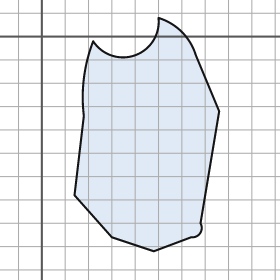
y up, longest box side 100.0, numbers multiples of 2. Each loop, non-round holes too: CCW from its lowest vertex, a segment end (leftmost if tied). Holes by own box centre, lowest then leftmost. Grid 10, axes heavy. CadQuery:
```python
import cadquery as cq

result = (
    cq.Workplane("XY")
    .moveTo(48.0, -92.0)
    .lineTo(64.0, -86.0)
    .threePointArc((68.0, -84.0), (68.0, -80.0))
    .lineTo(76.0, -32.0)
    .lineTo(66.0, -8.0)
    .threePointArc((60.0, 2.0), (50.0, 8.0))
    .threePointArc((40.0, -8.0), (22.0, -2.0))
    .threePointArc((18.0, -18.0), (18.0, -34.0))
    .lineTo(14.0, -68.0)
    .lineTo(30.0, -86.0)
    .close()
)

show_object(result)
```